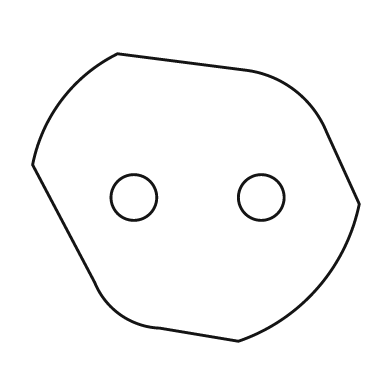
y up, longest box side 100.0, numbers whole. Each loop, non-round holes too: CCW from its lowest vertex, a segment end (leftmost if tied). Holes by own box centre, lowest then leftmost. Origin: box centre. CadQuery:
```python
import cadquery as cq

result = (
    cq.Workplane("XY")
    .moveTo(13.0, -44.0)
    .threePointArc((37.0, -28.0), (50.0, -2.0))
    .lineTo(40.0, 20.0)
    .threePointArc((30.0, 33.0), (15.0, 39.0))
    .lineTo(-24.0, 44.0)
    .threePointArc((-41.0, 30.0), (-50.0, 10.0))
    .lineTo(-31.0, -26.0)
    .threePointArc((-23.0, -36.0), (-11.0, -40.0))
    .close()
    .moveTo(-19.0, 0.0)
    .circle(7.0)
    .moveTo(20.0, 0.0)
    .circle(7.0)
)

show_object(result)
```